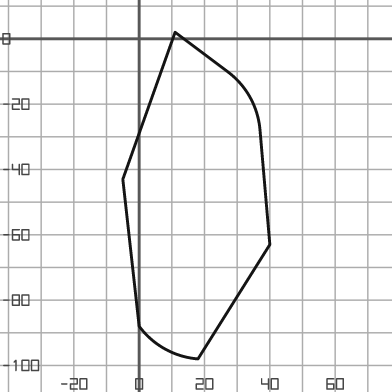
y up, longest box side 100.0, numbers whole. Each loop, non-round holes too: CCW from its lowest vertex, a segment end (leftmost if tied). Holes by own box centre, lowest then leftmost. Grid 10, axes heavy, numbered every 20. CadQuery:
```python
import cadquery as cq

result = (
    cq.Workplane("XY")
    .moveTo(18.0, -98.0)
    .lineTo(40.0, -63.0)
    .lineTo(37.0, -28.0)
    .threePointArc((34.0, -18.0), (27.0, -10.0))
    .lineTo(11.0, 2.0)
    .lineTo(-5.0, -43.0)
    .lineTo(0.0, -88.0)
    .threePointArc((8.0, -95.0), (18.0, -98.0))
    .close()
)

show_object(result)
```